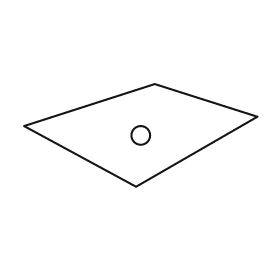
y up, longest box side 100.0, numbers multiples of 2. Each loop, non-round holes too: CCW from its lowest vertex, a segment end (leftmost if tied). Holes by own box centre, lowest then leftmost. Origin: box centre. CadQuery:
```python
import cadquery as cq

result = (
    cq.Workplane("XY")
    .moveTo(-2.0, -22.0)
    .lineTo(50.0, 8.0)
    .lineTo(6.0, 22.0)
    .lineTo(-50.0, 4.0)
    .close()
    .moveTo(0.0, 0.0)
    .circle(4.0)
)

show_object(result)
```